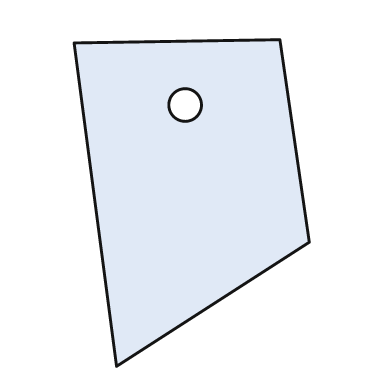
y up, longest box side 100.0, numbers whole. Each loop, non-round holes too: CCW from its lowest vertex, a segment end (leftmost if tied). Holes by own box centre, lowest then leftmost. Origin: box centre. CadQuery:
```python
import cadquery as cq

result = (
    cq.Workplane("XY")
    .moveTo(-23.0, -50.0)
    .lineTo(36.0, -12.0)
    .lineTo(27.0, 50.0)
    .lineTo(-36.0, 49.0)
    .close()
    .moveTo(-2.0, 30.0)
    .circle(5.0)
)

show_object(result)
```